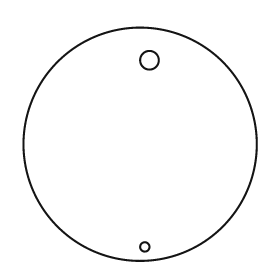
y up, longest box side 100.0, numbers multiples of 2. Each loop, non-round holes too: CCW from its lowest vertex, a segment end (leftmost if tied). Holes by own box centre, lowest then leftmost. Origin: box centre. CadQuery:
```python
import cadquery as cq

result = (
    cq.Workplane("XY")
    .moveTo(0.0, 0.0)
    .circle(50.0)
    .moveTo(2.0, -44.0)
    .circle(2.0)
    .moveTo(4.0, 36.0)
    .circle(4.0)
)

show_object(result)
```